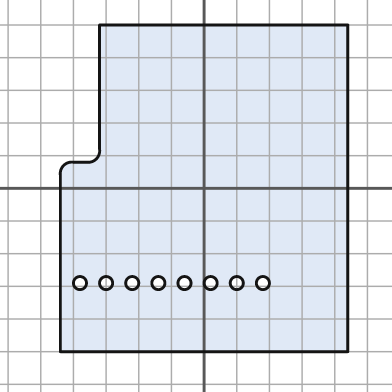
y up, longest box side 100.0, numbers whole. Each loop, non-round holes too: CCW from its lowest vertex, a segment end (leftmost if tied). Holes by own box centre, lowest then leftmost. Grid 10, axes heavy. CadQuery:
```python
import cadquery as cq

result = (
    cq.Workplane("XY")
    .moveTo(-44.0, -50.0)
    .lineTo(44.0, -50.0)
    .lineTo(44.0, 50.0)
    .lineTo(-32.0, 50.0)
    .lineTo(-32.0, 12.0)
    .threePointArc((-33.0, 9.0), (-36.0, 8.0))
    .lineTo(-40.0, 8.0)
    .threePointArc((-43.0, 7.0), (-44.0, 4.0))
    .close()
    .moveTo(-38.0, -29.0)
    .circle(2.0)
    .moveTo(-30.0, -29.0)
    .circle(2.0)
    .moveTo(-22.0, -29.0)
    .circle(2.0)
    .moveTo(-14.0, -29.0)
    .circle(2.0)
    .moveTo(-6.0, -29.0)
    .circle(2.0)
    .moveTo(2.0, -29.0)
    .circle(2.0)
    .moveTo(10.0, -29.0)
    .circle(2.0)
    .moveTo(18.0, -29.0)
    .circle(2.0)
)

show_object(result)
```